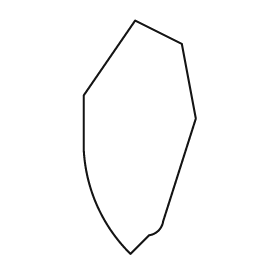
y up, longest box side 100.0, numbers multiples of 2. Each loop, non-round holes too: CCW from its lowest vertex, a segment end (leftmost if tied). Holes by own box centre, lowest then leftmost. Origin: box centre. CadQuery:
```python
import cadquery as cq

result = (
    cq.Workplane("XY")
    .moveTo(-4.0, -50.0)
    .lineTo(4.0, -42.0)
    .threePointArc((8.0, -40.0), (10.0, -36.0))
    .lineTo(24.0, 8.0)
    .lineTo(18.0, 40.0)
    .lineTo(-2.0, 50.0)
    .lineTo(-24.0, 18.0)
    .lineTo(-24.0, -6.0)
    .threePointArc((-18.0, -30.0), (-4.0, -50.0))
    .close()
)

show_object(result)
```